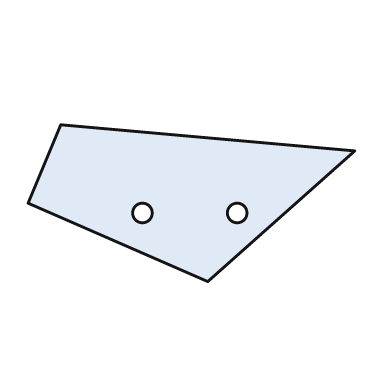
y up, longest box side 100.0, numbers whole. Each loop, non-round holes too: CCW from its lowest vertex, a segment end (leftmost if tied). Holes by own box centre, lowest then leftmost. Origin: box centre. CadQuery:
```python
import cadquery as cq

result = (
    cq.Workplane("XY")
    .moveTo(5.0, -24.0)
    .lineTo(50.0, 16.0)
    .lineTo(-40.0, 24.0)
    .lineTo(-50.0, 0.0)
    .close()
    .moveTo(-15.0, -3.0)
    .circle(3.0)
    .moveTo(14.0, -3.0)
    .circle(3.0)
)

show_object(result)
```